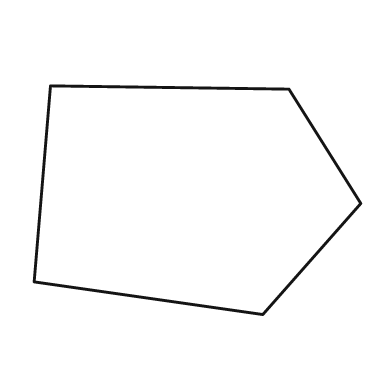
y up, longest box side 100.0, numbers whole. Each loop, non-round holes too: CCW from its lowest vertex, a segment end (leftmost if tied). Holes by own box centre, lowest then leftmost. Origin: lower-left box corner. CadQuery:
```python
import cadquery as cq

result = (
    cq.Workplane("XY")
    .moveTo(70.0, 0.0)
    .lineTo(100.0, 34.0)
    .lineTo(78.0, 69.0)
    .lineTo(5.0, 70.0)
    .lineTo(0.0, 10.0)
    .close()
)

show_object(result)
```